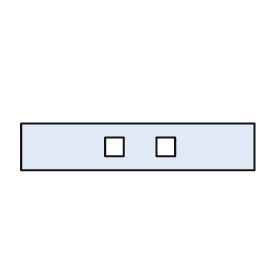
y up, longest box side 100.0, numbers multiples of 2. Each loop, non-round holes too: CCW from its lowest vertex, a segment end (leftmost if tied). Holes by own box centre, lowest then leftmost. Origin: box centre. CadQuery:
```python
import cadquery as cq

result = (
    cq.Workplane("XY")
    .moveTo(-50.0, -10.0)
    .lineTo(50.0, -10.0)
    .lineTo(50.0, 10.0)
    .lineTo(-50.0, 10.0)
    .close()
    .moveTo(-14.0, -4.0)
    .lineTo(-6.0, -4.0)
    .lineTo(-6.0, 4.0)
    .lineTo(-14.0, 4.0)
    .close()
    .moveTo(8.0, -4.0)
    .lineTo(16.0, -4.0)
    .lineTo(16.0, 4.0)
    .lineTo(8.0, 4.0)
    .close()
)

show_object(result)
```